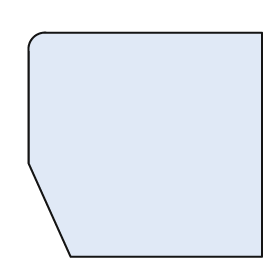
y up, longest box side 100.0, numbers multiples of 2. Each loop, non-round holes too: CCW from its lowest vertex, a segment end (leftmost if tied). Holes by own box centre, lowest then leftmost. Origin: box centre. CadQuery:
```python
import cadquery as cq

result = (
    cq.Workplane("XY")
    .moveTo(-32.0, -48.0)
    .lineTo(50.0, -48.0)
    .lineTo(50.0, 48.0)
    .lineTo(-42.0, 48.0)
    .threePointArc((-48.0, 46.0), (-50.0, 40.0))
    .lineTo(-50.0, -8.0)
    .close()
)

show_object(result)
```